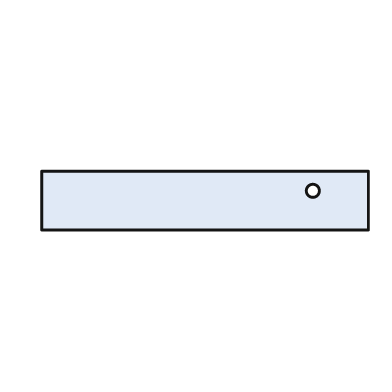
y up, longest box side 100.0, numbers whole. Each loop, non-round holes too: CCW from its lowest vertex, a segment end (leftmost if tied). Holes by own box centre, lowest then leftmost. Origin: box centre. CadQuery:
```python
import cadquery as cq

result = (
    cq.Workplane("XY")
    .moveTo(-50.0, -9.0)
    .lineTo(50.0, -9.0)
    .lineTo(50.0, 9.0)
    .lineTo(-50.0, 9.0)
    .close()
    .moveTo(33.0, 3.0)
    .circle(2.0)
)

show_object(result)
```